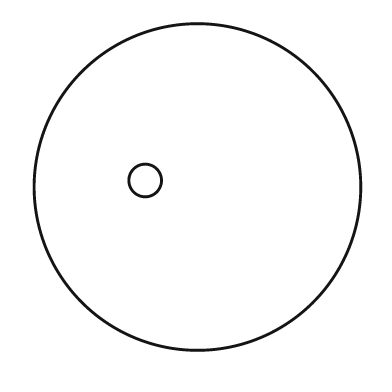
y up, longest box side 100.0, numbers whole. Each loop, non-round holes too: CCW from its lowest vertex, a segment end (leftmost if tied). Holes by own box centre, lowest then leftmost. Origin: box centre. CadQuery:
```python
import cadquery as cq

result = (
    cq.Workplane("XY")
    .moveTo(0.0, 0.0)
    .circle(50.0)
    .moveTo(-16.0, 2.0)
    .circle(5.0)
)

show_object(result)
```